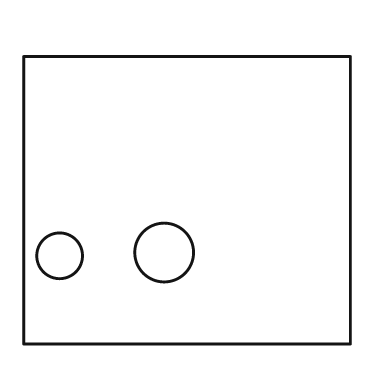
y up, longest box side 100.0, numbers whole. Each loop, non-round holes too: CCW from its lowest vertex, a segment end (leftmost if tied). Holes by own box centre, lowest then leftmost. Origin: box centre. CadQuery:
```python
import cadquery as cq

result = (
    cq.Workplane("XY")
    .moveTo(-50.0, -44.0)
    .lineTo(50.0, -44.0)
    .lineTo(50.0, 44.0)
    .lineTo(-50.0, 44.0)
    .close()
    .moveTo(-39.0, -17.0)
    .circle(7.0)
    .moveTo(-7.0, -16.0)
    .circle(9.0)
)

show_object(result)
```